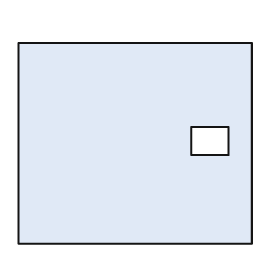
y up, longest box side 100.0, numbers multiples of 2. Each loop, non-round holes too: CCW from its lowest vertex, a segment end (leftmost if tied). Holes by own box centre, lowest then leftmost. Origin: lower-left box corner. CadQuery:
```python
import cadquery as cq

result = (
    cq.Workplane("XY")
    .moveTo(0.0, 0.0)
    .lineTo(100.0, 0.0)
    .lineTo(100.0, 86.0)
    .lineTo(0.0, 86.0)
    .close()
    .moveTo(74.0, 38.0)
    .lineTo(90.0, 38.0)
    .lineTo(90.0, 50.0)
    .lineTo(74.0, 50.0)
    .close()
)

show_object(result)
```